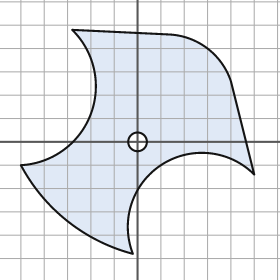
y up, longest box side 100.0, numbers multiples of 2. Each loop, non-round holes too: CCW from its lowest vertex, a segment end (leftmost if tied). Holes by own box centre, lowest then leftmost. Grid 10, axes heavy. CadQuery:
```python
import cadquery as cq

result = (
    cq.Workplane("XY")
    .moveTo(-2.0, -48.0)
    .threePointArc((10.0, -10.0), (50.0, -14.0))
    .lineTo(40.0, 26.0)
    .threePointArc((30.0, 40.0), (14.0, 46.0))
    .lineTo(-28.0, 48.0)
    .threePointArc((-20.0, 12.0), (-50.0, -10.0))
    .threePointArc((-30.0, -34.0), (-2.0, -48.0))
    .close()
    .moveTo(0.0, 0.0)
    .circle(4.0)
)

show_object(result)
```